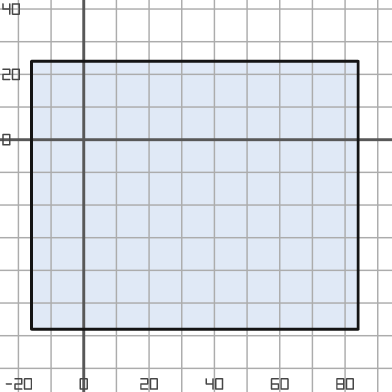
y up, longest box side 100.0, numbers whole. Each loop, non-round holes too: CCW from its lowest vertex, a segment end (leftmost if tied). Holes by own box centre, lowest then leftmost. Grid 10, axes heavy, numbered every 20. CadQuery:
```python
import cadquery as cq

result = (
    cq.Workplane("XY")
    .moveTo(-16.0, -58.0)
    .lineTo(84.0, -58.0)
    .lineTo(84.0, 24.0)
    .lineTo(-16.0, 24.0)
    .close()
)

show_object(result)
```